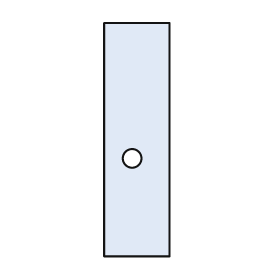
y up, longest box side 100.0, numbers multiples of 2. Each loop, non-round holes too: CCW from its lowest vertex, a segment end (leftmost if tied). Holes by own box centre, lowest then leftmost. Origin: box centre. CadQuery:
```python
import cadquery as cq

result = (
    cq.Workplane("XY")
    .moveTo(-14.0, -50.0)
    .lineTo(14.0, -50.0)
    .lineTo(14.0, 50.0)
    .lineTo(-14.0, 50.0)
    .close()
    .moveTo(-2.0, -8.0)
    .circle(4.0)
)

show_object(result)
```